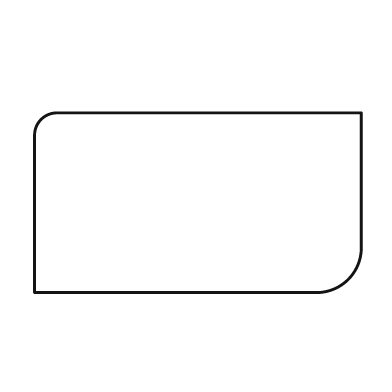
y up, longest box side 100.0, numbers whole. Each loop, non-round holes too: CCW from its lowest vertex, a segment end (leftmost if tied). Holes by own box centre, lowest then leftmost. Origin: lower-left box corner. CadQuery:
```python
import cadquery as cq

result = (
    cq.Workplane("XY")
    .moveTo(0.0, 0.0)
    .lineTo(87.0, 0.0)
    .threePointArc((96.0, 4.0), (100.0, 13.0))
    .lineTo(100.0, 55.0)
    .lineTo(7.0, 55.0)
    .threePointArc((2.0, 53.0), (0.0, 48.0))
    .close()
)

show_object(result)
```